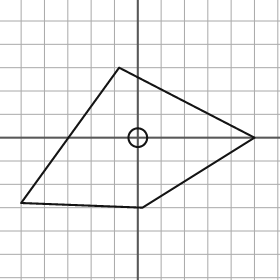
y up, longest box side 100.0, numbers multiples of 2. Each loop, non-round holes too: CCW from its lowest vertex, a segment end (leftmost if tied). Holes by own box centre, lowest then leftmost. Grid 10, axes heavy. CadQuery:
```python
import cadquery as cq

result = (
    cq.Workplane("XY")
    .moveTo(2.0, -30.0)
    .lineTo(50.0, 0.0)
    .lineTo(-8.0, 30.0)
    .lineTo(-50.0, -28.0)
    .close()
    .moveTo(0.0, 0.0)
    .circle(4.0)
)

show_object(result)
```